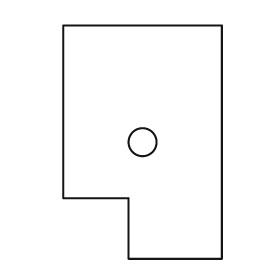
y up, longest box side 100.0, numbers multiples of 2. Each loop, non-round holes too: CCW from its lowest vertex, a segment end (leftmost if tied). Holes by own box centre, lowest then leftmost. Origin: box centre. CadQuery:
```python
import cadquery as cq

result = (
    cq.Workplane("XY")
    .moveTo(-6.0, -50.0)
    .lineTo(34.0, -50.0)
    .lineTo(34.0, 50.0)
    .lineTo(-34.0, 50.0)
    .lineTo(-34.0, -24.0)
    .lineTo(-6.0, -24.0)
    .close()
    .moveTo(0.0, 0.0)
    .circle(6.0)
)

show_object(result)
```